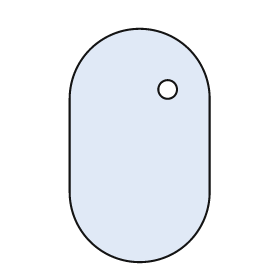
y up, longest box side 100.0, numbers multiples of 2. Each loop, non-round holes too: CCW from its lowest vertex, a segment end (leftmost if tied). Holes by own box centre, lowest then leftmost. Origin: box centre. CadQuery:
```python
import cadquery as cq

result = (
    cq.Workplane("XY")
    .moveTo(-30.0, -20.0)
    .threePointArc((0.0, -50.0), (30.0, -20.0))
    .lineTo(30.0, 20.0)
    .threePointArc((0.0, 50.0), (-30.0, 20.0))
    .close()
    .moveTo(12.0, 24.0)
    .circle(4.0)
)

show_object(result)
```